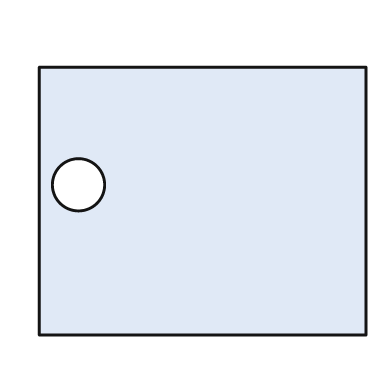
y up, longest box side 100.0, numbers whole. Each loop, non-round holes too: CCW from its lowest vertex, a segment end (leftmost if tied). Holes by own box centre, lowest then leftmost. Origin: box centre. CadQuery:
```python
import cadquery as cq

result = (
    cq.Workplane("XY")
    .moveTo(-50.0, -41.0)
    .lineTo(50.0, -41.0)
    .lineTo(50.0, 41.0)
    .lineTo(-50.0, 41.0)
    .close()
    .moveTo(-38.0, 5.0)
    .circle(8.0)
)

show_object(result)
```